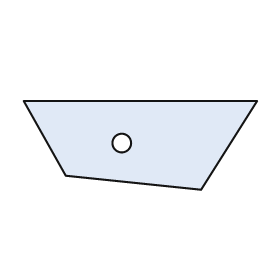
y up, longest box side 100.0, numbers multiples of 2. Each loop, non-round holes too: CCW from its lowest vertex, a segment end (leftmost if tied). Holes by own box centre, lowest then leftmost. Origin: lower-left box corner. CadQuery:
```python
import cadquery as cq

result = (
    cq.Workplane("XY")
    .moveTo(76.0, 0.0)
    .lineTo(100.0, 38.0)
    .lineTo(0.0, 38.0)
    .lineTo(18.0, 6.0)
    .close()
    .moveTo(42.0, 20.0)
    .circle(4.0)
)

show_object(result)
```